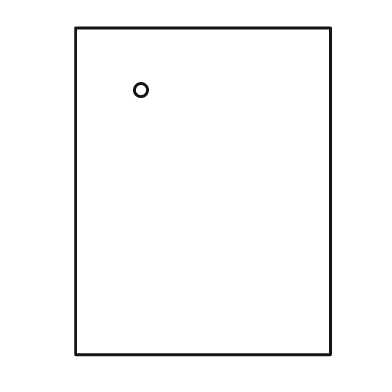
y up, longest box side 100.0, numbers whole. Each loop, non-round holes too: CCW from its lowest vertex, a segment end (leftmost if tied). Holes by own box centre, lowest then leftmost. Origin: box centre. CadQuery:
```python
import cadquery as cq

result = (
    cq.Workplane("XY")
    .moveTo(-39.0, -50.0)
    .lineTo(39.0, -50.0)
    .lineTo(39.0, 50.0)
    .lineTo(-39.0, 50.0)
    .close()
    .moveTo(-19.0, 31.0)
    .circle(2.0)
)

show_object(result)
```